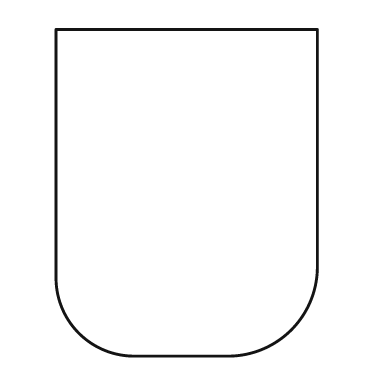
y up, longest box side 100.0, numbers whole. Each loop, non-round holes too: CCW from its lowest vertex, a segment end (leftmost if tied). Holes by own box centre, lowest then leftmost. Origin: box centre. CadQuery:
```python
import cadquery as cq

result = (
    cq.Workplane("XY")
    .moveTo(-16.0, -50.0)
    .lineTo(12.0, -50.0)
    .threePointArc((32.0, -42.0), (40.0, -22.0))
    .lineTo(40.0, 50.0)
    .lineTo(-40.0, 50.0)
    .lineTo(-40.0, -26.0)
    .threePointArc((-33.0, -43.0), (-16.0, -50.0))
    .close()
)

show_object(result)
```